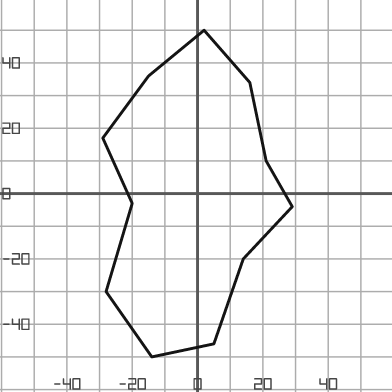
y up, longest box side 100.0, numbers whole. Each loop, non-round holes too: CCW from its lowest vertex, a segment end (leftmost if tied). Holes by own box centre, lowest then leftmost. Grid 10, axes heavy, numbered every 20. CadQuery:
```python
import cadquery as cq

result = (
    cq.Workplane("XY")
    .moveTo(-14.0, -50.0)
    .lineTo(5.0, -46.0)
    .lineTo(14.0, -20.0)
    .lineTo(29.0, -4.0)
    .lineTo(21.0, 10.0)
    .lineTo(16.0, 34.0)
    .lineTo(2.0, 50.0)
    .lineTo(-15.0, 36.0)
    .lineTo(-29.0, 17.0)
    .lineTo(-20.0, -3.0)
    .lineTo(-28.0, -30.0)
    .close()
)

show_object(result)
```